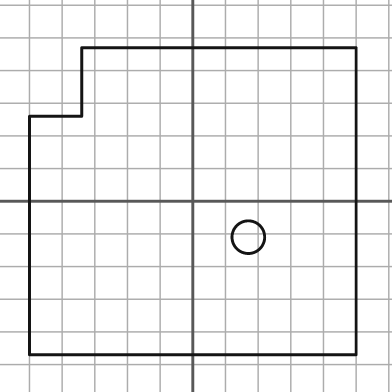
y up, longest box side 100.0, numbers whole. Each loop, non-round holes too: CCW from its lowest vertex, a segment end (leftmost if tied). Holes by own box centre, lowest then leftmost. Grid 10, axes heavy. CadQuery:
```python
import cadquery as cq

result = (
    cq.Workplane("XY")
    .moveTo(-50.0, -47.0)
    .lineTo(50.0, -47.0)
    .lineTo(50.0, 47.0)
    .lineTo(-34.0, 47.0)
    .lineTo(-34.0, 26.0)
    .lineTo(-50.0, 26.0)
    .close()
    .moveTo(17.0, -11.0)
    .circle(5.0)
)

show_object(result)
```